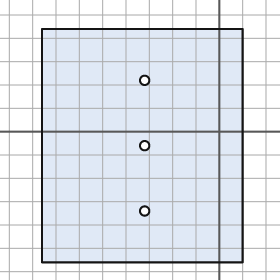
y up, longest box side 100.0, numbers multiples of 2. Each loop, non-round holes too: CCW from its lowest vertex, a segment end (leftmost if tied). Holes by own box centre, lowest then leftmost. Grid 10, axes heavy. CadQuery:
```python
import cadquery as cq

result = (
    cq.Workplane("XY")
    .moveTo(-76.0, -56.0)
    .lineTo(10.0, -56.0)
    .lineTo(10.0, 44.0)
    .lineTo(-76.0, 44.0)
    .close()
    .moveTo(-32.0, -34.0)
    .circle(2.0)
    .moveTo(-32.0, -6.0)
    .circle(2.0)
    .moveTo(-32.0, 22.0)
    .circle(2.0)
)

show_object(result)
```